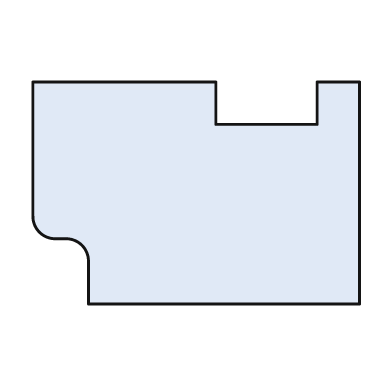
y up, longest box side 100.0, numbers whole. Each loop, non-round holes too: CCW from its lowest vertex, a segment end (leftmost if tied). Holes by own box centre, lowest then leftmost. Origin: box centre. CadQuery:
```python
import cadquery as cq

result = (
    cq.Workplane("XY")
    .moveTo(-33.0, -34.0)
    .lineTo(50.0, -34.0)
    .lineTo(50.0, 34.0)
    .lineTo(37.0, 34.0)
    .lineTo(37.0, 21.0)
    .lineTo(6.0, 21.0)
    .lineTo(6.0, 34.0)
    .lineTo(-50.0, 34.0)
    .lineTo(-50.0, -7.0)
    .threePointArc((-48.0, -12.0), (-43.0, -14.0))
    .lineTo(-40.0, -14.0)
    .threePointArc((-35.0, -16.0), (-33.0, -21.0))
    .close()
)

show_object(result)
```